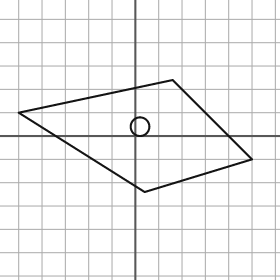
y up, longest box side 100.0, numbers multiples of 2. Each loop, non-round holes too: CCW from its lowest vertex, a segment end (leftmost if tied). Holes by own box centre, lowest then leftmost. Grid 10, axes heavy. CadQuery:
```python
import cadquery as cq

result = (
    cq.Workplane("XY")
    .moveTo(4.0, -24.0)
    .lineTo(50.0, -10.0)
    .lineTo(16.0, 24.0)
    .lineTo(-50.0, 10.0)
    .close()
    .moveTo(2.0, 4.0)
    .circle(4.0)
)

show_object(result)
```